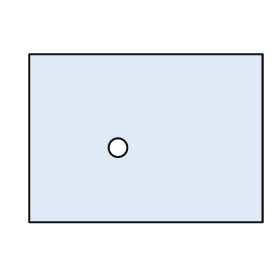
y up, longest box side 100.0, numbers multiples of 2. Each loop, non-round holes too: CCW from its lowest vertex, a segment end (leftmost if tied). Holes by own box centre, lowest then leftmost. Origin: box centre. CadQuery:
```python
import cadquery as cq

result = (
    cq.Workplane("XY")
    .moveTo(-50.0, -36.0)
    .lineTo(50.0, -36.0)
    .lineTo(50.0, 36.0)
    .lineTo(-50.0, 36.0)
    .close()
    .moveTo(-12.0, -4.0)
    .circle(4.0)
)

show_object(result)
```